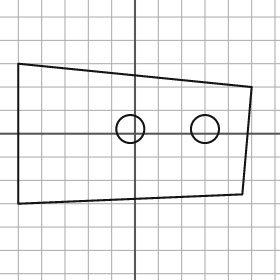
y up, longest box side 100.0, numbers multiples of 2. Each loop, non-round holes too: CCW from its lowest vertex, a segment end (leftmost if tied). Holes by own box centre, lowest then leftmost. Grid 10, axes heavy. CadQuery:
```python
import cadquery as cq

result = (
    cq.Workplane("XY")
    .moveTo(-50.0, -30.0)
    .lineTo(46.0, -26.0)
    .lineTo(50.0, 20.0)
    .lineTo(-50.0, 30.0)
    .close()
    .moveTo(-2.0, 2.0)
    .circle(6.0)
    .moveTo(30.0, 2.0)
    .circle(6.0)
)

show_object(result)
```